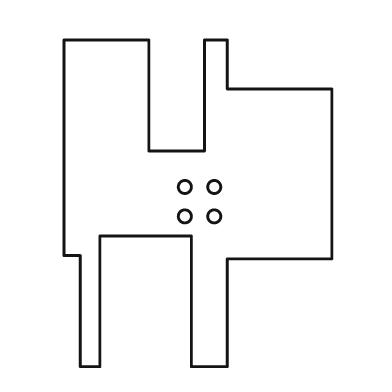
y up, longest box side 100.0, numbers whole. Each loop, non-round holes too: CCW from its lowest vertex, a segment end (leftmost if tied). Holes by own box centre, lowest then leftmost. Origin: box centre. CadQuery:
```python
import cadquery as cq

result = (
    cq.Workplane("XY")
    .moveTo(-36.0, -50.0)
    .lineTo(-30.0, -50.0)
    .lineTo(-30.0, -10.0)
    .lineTo(-2.0, -10.0)
    .lineTo(-2.0, -50.0)
    .lineTo(9.0, -50.0)
    .lineTo(9.0, -17.0)
    .lineTo(41.0, -17.0)
    .lineTo(41.0, 35.0)
    .lineTo(9.0, 35.0)
    .lineTo(9.0, 50.0)
    .lineTo(2.0, 50.0)
    .lineTo(2.0, 16.0)
    .lineTo(-15.0, 16.0)
    .lineTo(-15.0, 50.0)
    .lineTo(-41.0, 50.0)
    .lineTo(-41.0, -16.0)
    .lineTo(-36.0, -16.0)
    .close()
    .moveTo(-4.0, -4.0)
    .circle(2.0)
    .moveTo(5.0, -4.0)
    .circle(2.0)
    .moveTo(-4.0, 5.0)
    .circle(2.0)
    .moveTo(5.0, 5.0)
    .circle(2.0)
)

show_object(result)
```